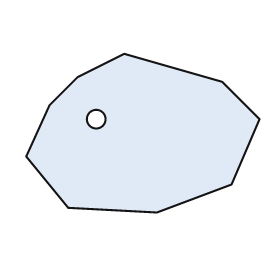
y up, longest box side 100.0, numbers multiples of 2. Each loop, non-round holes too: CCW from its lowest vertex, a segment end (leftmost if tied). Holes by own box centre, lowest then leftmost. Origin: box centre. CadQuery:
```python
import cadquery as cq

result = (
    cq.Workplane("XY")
    .moveTo(6.0, -34.0)
    .lineTo(38.0, -22.0)
    .lineTo(50.0, 6.0)
    .lineTo(34.0, 22.0)
    .lineTo(-8.0, 34.0)
    .lineTo(-28.0, 24.0)
    .lineTo(-40.0, 12.0)
    .lineTo(-50.0, -10.0)
    .lineTo(-32.0, -32.0)
    .close()
    .moveTo(-20.0, 6.0)
    .circle(4.0)
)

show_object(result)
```